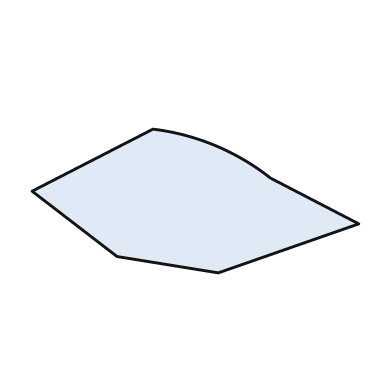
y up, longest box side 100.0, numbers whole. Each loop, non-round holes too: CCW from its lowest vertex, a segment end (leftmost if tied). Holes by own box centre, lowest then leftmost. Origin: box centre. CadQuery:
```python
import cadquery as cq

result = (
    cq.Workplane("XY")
    .moveTo(7.0, -22.0)
    .lineTo(50.0, -7.0)
    .lineTo(23.0, 7.0)
    .threePointArc((6.0, 17.0), (-13.0, 22.0))
    .lineTo(-50.0, 3.0)
    .lineTo(-24.0, -17.0)
    .close()
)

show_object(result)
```